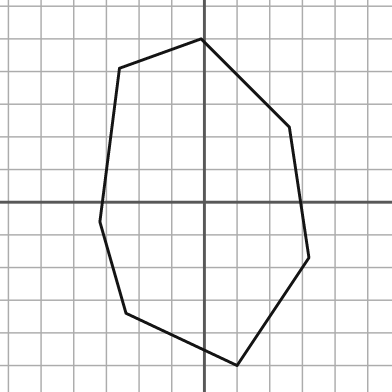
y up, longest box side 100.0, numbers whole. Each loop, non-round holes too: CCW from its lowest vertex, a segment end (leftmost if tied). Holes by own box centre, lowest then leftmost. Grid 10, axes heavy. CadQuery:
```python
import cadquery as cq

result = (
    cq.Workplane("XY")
    .moveTo(10.0, -50.0)
    .lineTo(32.0, -17.0)
    .lineTo(26.0, 23.0)
    .lineTo(-1.0, 50.0)
    .lineTo(-26.0, 41.0)
    .lineTo(-32.0, -6.0)
    .lineTo(-24.0, -34.0)
    .close()
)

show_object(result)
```